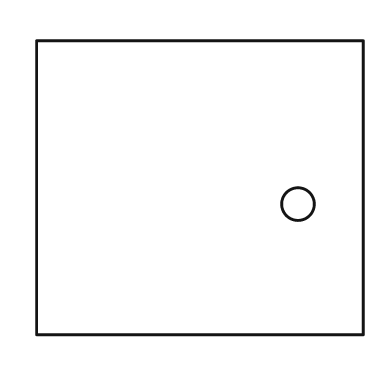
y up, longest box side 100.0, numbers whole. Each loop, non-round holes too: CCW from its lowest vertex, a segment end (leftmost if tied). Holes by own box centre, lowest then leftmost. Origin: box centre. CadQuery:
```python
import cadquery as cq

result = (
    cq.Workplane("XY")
    .moveTo(-50.0, -45.0)
    .lineTo(50.0, -45.0)
    .lineTo(50.0, 45.0)
    .lineTo(-50.0, 45.0)
    .close()
    .moveTo(30.0, -5.0)
    .circle(5.0)
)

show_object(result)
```